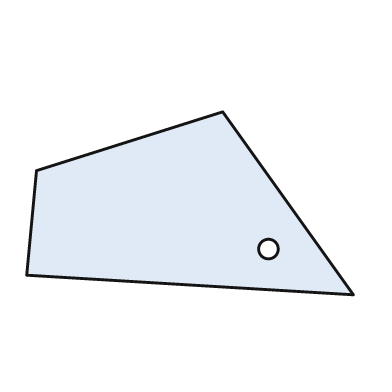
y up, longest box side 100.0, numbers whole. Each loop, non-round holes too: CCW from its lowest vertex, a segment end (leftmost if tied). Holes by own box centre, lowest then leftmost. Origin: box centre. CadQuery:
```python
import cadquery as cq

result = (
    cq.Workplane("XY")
    .moveTo(50.0, -28.0)
    .lineTo(10.0, 28.0)
    .lineTo(-47.0, 10.0)
    .lineTo(-50.0, -22.0)
    .close()
    .moveTo(24.0, -14.0)
    .circle(3.0)
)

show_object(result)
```